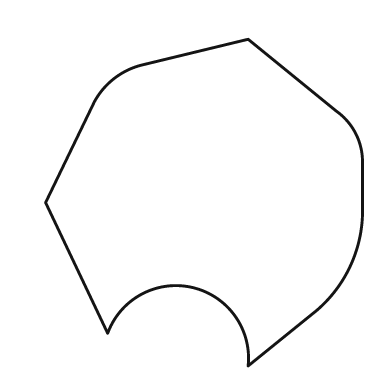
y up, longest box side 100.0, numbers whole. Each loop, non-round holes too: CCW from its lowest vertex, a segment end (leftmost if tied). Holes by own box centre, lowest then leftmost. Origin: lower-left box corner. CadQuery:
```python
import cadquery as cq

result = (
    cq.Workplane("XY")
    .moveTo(62.0, 0.0)
    .lineTo(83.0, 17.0)
    .threePointArc((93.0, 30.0), (97.0, 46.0))
    .lineTo(97.0, 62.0)
    .threePointArc((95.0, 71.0), (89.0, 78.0))
    .lineTo(62.0, 100.0)
    .lineTo(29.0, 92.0)
    .threePointArc((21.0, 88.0), (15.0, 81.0))
    .lineTo(0.0, 50.0)
    .lineTo(19.0, 10.0)
    .threePointArc((45.0, 24.0), (62.0, 0.0))
    .close()
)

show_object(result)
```